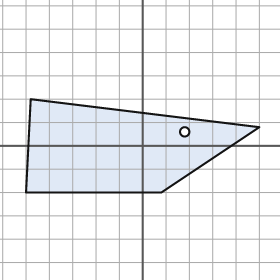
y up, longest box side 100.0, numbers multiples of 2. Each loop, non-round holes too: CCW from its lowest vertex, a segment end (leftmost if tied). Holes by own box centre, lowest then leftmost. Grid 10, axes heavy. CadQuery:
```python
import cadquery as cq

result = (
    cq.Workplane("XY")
    .moveTo(-50.0, -20.0)
    .lineTo(8.0, -20.0)
    .lineTo(50.0, 8.0)
    .lineTo(-48.0, 20.0)
    .close()
    .moveTo(18.0, 6.0)
    .circle(2.0)
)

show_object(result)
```